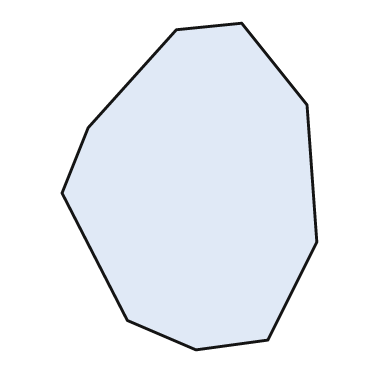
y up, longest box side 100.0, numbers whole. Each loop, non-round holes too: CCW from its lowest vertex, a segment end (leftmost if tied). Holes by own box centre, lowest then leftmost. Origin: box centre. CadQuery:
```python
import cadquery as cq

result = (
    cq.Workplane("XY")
    .moveTo(2.0, -50.0)
    .lineTo(24.0, -47.0)
    .lineTo(39.0, -17.0)
    .lineTo(36.0, 25.0)
    .lineTo(16.0, 50.0)
    .lineTo(-4.0, 48.0)
    .lineTo(-31.0, 18.0)
    .lineTo(-39.0, -2.0)
    .lineTo(-19.0, -41.0)
    .close()
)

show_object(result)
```